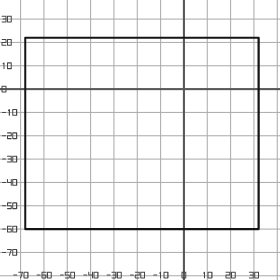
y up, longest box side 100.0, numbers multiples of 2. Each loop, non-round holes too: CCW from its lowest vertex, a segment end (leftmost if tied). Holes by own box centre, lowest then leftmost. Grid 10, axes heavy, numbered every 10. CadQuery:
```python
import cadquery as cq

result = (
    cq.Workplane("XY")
    .moveTo(-68.0, -60.0)
    .lineTo(32.0, -60.0)
    .lineTo(32.0, 22.0)
    .lineTo(-68.0, 22.0)
    .close()
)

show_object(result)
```